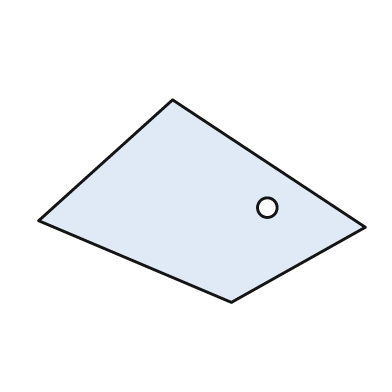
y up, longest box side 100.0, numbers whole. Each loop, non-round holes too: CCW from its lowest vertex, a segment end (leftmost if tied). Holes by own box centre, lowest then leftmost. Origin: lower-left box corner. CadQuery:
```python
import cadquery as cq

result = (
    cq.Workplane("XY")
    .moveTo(59.0, 0.0)
    .lineTo(100.0, 23.0)
    .lineTo(41.0, 62.0)
    .lineTo(0.0, 25.0)
    .close()
    .moveTo(70.0, 29.0)
    .circle(3.0)
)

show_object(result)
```